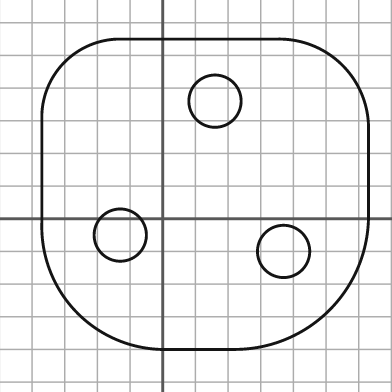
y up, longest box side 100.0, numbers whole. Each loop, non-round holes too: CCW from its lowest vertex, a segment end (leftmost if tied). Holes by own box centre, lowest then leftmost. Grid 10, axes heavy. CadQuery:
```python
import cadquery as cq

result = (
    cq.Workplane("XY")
    .moveTo(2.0, -40.0)
    .lineTo(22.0, -40.0)
    .threePointArc((51.0, -28.0), (63.0, 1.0))
    .lineTo(63.0, 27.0)
    .threePointArc((55.0, 47.0), (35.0, 55.0))
    .lineTo(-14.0, 55.0)
    .threePointArc((-30.0, 48.0), (-37.0, 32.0))
    .lineTo(-37.0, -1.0)
    .threePointArc((-26.0, -29.0), (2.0, -40.0))
    .close()
    .moveTo(37.0, -10.0)
    .circle(8.0)
    .moveTo(-13.0, -5.0)
    .circle(8.0)
    .moveTo(16.0, 36.0)
    .circle(8.0)
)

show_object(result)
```